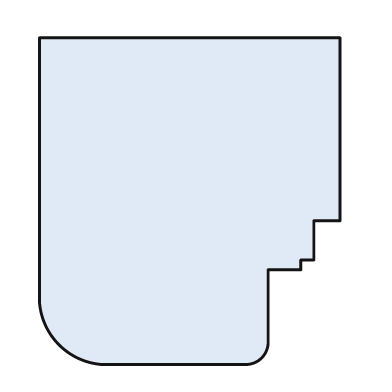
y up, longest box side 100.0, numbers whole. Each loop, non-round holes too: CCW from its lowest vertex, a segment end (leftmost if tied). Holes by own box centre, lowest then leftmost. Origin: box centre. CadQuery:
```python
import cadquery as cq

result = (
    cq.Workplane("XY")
    .moveTo(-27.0, -50.0)
    .lineTo(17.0, -50.0)
    .threePointArc((22.0, -48.0), (24.0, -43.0))
    .lineTo(24.0, -21.0)
    .lineTo(34.0, -21.0)
    .lineTo(34.0, -18.0)
    .lineTo(38.0, -18.0)
    .lineTo(38.0, -6.0)
    .lineTo(46.0, -6.0)
    .lineTo(46.0, 50.0)
    .lineTo(-46.0, 50.0)
    .lineTo(-46.0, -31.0)
    .threePointArc((-40.0, -44.0), (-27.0, -50.0))
    .close()
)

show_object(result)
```